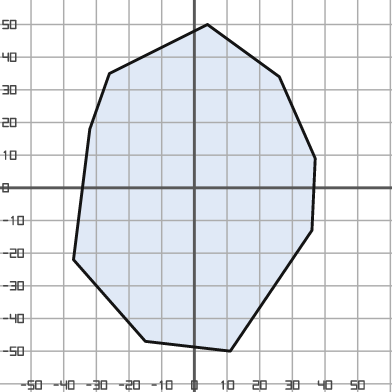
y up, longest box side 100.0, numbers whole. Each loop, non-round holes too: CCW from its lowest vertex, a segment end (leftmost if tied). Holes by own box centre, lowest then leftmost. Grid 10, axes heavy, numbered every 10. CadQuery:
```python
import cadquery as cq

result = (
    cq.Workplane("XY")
    .moveTo(11.0, -50.0)
    .lineTo(36.0, -13.0)
    .lineTo(37.0, 9.0)
    .lineTo(26.0, 34.0)
    .lineTo(4.0, 50.0)
    .lineTo(-26.0, 35.0)
    .lineTo(-32.0, 18.0)
    .lineTo(-37.0, -22.0)
    .lineTo(-15.0, -47.0)
    .close()
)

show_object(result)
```